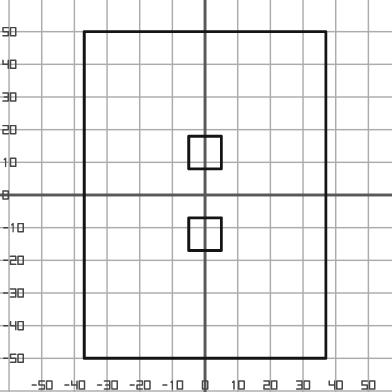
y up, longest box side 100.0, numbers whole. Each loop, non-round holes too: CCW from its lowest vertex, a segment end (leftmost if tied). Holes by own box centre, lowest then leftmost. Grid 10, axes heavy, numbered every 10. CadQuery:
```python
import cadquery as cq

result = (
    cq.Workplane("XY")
    .moveTo(-37.0, -50.0)
    .lineTo(37.0, -50.0)
    .lineTo(37.0, 50.0)
    .lineTo(-37.0, 50.0)
    .close()
    .moveTo(-5.0, -17.0)
    .lineTo(5.0, -17.0)
    .lineTo(5.0, -7.0)
    .lineTo(-5.0, -7.0)
    .close()
    .moveTo(-5.0, 8.0)
    .lineTo(5.0, 8.0)
    .lineTo(5.0, 18.0)
    .lineTo(-5.0, 18.0)
    .close()
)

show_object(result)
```